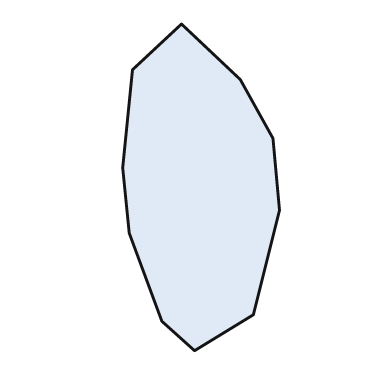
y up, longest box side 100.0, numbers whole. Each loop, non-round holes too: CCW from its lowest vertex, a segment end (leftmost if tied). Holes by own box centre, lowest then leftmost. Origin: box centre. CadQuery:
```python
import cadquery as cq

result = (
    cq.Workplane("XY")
    .moveTo(-2.0, -50.0)
    .lineTo(16.0, -39.0)
    .lineTo(24.0, -7.0)
    .lineTo(22.0, 15.0)
    .lineTo(12.0, 33.0)
    .lineTo(-6.0, 50.0)
    .lineTo(-21.0, 36.0)
    .lineTo(-24.0, 6.0)
    .lineTo(-22.0, -14.0)
    .lineTo(-12.0, -41.0)
    .close()
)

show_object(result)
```